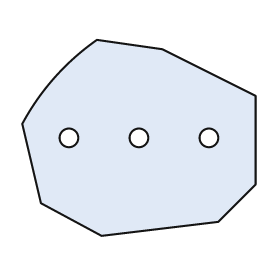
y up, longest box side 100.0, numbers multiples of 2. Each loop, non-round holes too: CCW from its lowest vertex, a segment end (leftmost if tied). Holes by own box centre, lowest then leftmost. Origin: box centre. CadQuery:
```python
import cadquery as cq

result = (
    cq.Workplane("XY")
    .moveTo(-16.0, -42.0)
    .lineTo(34.0, -36.0)
    .lineTo(50.0, -20.0)
    .lineTo(50.0, 18.0)
    .lineTo(10.0, 38.0)
    .lineTo(-18.0, 42.0)
    .threePointArc((-36.0, 26.0), (-50.0, 6.0))
    .lineTo(-42.0, -28.0)
    .close()
    .moveTo(-30.0, 0.0)
    .circle(4.0)
    .moveTo(0.0, 0.0)
    .circle(4.0)
    .moveTo(30.0, 0.0)
    .circle(4.0)
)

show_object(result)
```